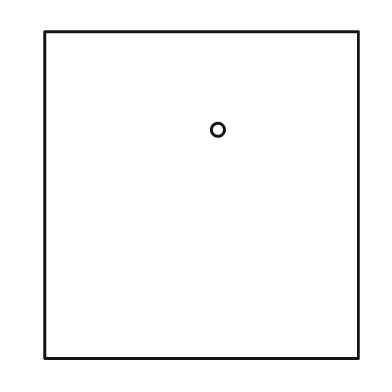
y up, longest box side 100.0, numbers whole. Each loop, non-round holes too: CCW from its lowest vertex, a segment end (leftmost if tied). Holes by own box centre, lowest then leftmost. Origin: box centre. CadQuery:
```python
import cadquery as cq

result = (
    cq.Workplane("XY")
    .moveTo(-48.0, -50.0)
    .lineTo(48.0, -50.0)
    .lineTo(48.0, 50.0)
    .lineTo(-48.0, 50.0)
    .close()
    .moveTo(5.0, 20.0)
    .circle(2.0)
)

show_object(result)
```